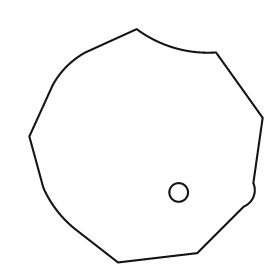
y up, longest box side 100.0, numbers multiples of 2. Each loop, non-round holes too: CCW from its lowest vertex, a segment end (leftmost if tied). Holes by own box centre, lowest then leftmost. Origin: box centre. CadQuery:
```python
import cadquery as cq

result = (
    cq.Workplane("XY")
    .moveTo(-12.0, -50.0)
    .lineTo(22.0, -46.0)
    .lineTo(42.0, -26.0)
    .threePointArc((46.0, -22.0), (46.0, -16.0))
    .lineTo(50.0, 12.0)
    .lineTo(30.0, 40.0)
    .threePointArc((12.0, 42.0), (-4.0, 50.0))
    .lineTo(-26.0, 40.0)
    .threePointArc((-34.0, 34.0), (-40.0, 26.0))
    .lineTo(-50.0, 4.0)
    .lineTo(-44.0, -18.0)
    .threePointArc((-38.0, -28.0), (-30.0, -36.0))
    .close()
    .moveTo(14.0, -20.0)
    .circle(4.0)
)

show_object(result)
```